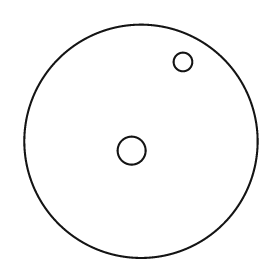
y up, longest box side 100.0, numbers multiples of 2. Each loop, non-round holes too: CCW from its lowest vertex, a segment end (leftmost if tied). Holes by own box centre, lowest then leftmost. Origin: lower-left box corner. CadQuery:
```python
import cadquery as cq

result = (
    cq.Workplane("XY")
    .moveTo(50.0, 50.0)
    .circle(50.0)
    .moveTo(46.0, 46.0)
    .circle(6.0)
    .moveTo(68.0, 84.0)
    .circle(4.0)
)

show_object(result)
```